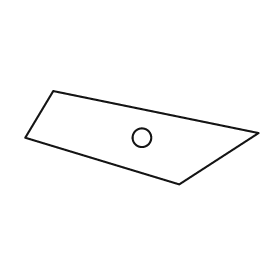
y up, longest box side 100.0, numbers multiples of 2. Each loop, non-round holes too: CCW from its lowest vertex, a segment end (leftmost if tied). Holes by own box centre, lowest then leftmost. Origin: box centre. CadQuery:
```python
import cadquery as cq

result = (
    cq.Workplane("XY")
    .moveTo(16.0, -20.0)
    .lineTo(50.0, 2.0)
    .lineTo(-38.0, 20.0)
    .lineTo(-50.0, 0.0)
    .close()
    .moveTo(0.0, 0.0)
    .circle(4.0)
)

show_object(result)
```